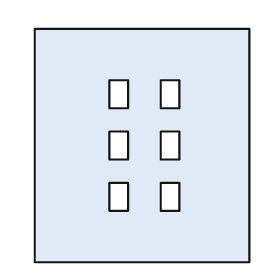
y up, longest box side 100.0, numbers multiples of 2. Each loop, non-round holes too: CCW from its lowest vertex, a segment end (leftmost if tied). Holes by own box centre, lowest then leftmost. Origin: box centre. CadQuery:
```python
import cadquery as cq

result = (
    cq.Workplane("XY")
    .moveTo(-46.0, -50.0)
    .lineTo(46.0, -50.0)
    .lineTo(46.0, 50.0)
    .lineTo(-46.0, 50.0)
    .close()
    .moveTo(-14.0, -28.0)
    .lineTo(-6.0, -28.0)
    .lineTo(-6.0, -16.0)
    .lineTo(-14.0, -16.0)
    .close()
    .moveTo(8.0, -28.0)
    .lineTo(16.0, -28.0)
    .lineTo(16.0, -16.0)
    .lineTo(8.0, -16.0)
    .close()
    .moveTo(-14.0, -6.0)
    .lineTo(-6.0, -6.0)
    .lineTo(-6.0, 6.0)
    .lineTo(-14.0, 6.0)
    .close()
    .moveTo(8.0, -6.0)
    .lineTo(16.0, -6.0)
    .lineTo(16.0, 6.0)
    .lineTo(8.0, 6.0)
    .close()
    .moveTo(-14.0, 16.0)
    .lineTo(-6.0, 16.0)
    .lineTo(-6.0, 28.0)
    .lineTo(-14.0, 28.0)
    .close()
    .moveTo(8.0, 16.0)
    .lineTo(16.0, 16.0)
    .lineTo(16.0, 28.0)
    .lineTo(8.0, 28.0)
    .close()
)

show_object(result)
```